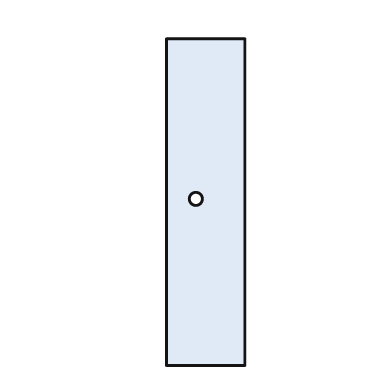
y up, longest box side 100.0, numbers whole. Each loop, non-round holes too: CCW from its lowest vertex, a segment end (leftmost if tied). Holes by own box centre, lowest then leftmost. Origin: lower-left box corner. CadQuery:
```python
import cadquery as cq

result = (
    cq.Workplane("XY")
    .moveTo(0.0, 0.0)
    .lineTo(24.0, 0.0)
    .lineTo(24.0, 100.0)
    .lineTo(0.0, 100.0)
    .close()
    .moveTo(9.0, 51.0)
    .circle(2.0)
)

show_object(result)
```